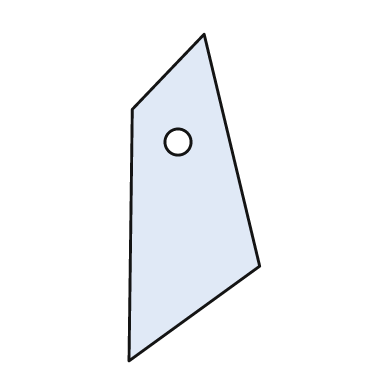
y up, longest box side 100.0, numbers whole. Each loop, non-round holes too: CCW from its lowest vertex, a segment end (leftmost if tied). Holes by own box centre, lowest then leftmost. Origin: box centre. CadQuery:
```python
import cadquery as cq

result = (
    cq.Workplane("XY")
    .moveTo(-20.0, -50.0)
    .lineTo(20.0, -21.0)
    .lineTo(3.0, 50.0)
    .lineTo(-19.0, 27.0)
    .close()
    .moveTo(-5.0, 17.0)
    .circle(4.0)
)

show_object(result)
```